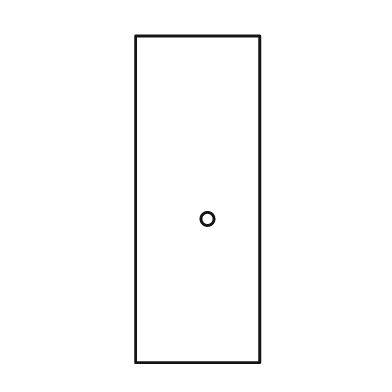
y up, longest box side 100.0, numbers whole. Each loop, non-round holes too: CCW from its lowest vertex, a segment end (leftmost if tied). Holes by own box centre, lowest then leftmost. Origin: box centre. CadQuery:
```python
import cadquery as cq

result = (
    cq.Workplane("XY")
    .moveTo(-19.0, -50.0)
    .lineTo(19.0, -50.0)
    .lineTo(19.0, 50.0)
    .lineTo(-19.0, 50.0)
    .close()
    .moveTo(3.0, -6.0)
    .circle(2.0)
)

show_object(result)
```